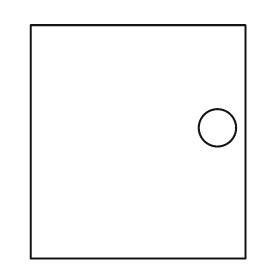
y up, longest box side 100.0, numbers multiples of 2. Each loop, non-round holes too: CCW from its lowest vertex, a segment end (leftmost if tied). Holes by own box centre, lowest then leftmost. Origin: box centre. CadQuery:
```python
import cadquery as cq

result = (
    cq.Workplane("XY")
    .moveTo(-46.0, -50.0)
    .lineTo(46.0, -50.0)
    .lineTo(46.0, 50.0)
    .lineTo(-46.0, 50.0)
    .close()
    .moveTo(34.0, 6.0)
    .circle(8.0)
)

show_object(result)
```